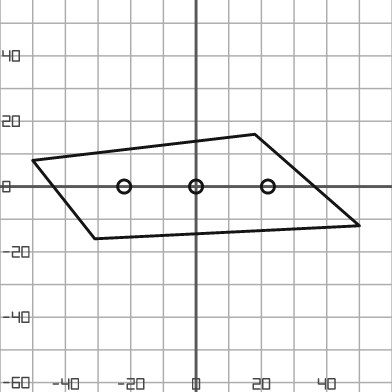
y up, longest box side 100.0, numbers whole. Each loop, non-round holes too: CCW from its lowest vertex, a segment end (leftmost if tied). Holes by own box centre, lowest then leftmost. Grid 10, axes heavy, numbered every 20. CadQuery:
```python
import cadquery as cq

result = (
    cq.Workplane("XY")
    .moveTo(-31.0, -16.0)
    .lineTo(50.0, -12.0)
    .lineTo(18.0, 16.0)
    .lineTo(-50.0, 8.0)
    .close()
    .moveTo(-22.0, 0.0)
    .circle(2.0)
    .moveTo(0.0, 0.0)
    .circle(2.0)
    .moveTo(22.0, 0.0)
    .circle(2.0)
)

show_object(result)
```